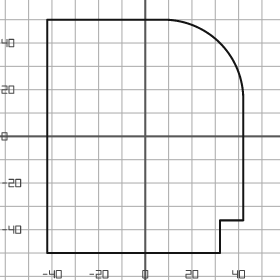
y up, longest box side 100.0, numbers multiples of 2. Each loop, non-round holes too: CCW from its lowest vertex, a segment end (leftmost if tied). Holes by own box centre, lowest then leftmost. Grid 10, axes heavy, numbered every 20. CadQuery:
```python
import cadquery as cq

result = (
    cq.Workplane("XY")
    .moveTo(-42.0, -50.0)
    .lineTo(32.0, -50.0)
    .lineTo(32.0, -36.0)
    .lineTo(42.0, -36.0)
    .lineTo(42.0, 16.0)
    .threePointArc((32.0, 40.0), (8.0, 50.0))
    .lineTo(-42.0, 50.0)
    .close()
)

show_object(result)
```